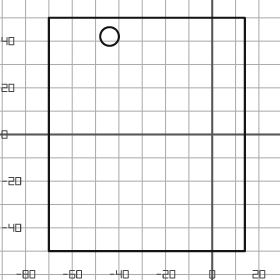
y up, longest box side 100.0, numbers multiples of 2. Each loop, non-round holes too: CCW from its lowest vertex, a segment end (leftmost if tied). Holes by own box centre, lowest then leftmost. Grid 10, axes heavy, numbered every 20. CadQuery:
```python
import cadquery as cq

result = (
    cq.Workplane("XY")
    .moveTo(-70.0, -50.0)
    .lineTo(14.0, -50.0)
    .lineTo(14.0, 50.0)
    .lineTo(-70.0, 50.0)
    .close()
    .moveTo(-44.0, 42.0)
    .circle(4.0)
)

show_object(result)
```